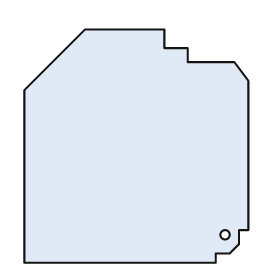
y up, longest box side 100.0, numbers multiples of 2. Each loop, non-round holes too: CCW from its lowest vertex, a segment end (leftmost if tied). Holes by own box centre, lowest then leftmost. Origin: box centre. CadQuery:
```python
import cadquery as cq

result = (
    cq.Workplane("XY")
    .moveTo(-48.0, -50.0)
    .lineTo(34.0, -50.0)
    .lineTo(34.0, -46.0)
    .lineTo(40.0, -46.0)
    .lineTo(44.0, -42.0)
    .lineTo(44.0, -36.0)
    .lineTo(48.0, -36.0)
    .lineTo(48.0, 28.0)
    .lineTo(42.0, 36.0)
    .lineTo(22.0, 36.0)
    .lineTo(22.0, 42.0)
    .lineTo(12.0, 42.0)
    .lineTo(12.0, 50.0)
    .lineTo(-22.0, 50.0)
    .lineTo(-48.0, 24.0)
    .close()
    .moveTo(38.0, -38.0)
    .circle(2.0)
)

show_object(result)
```